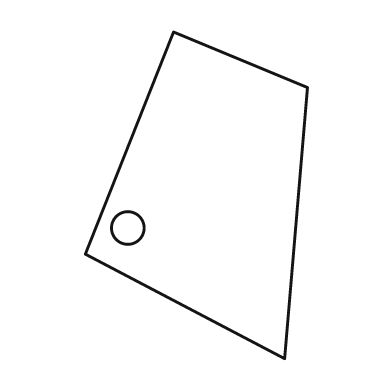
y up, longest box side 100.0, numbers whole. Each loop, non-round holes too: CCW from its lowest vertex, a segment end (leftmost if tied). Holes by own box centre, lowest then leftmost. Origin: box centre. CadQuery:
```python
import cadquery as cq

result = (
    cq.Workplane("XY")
    .moveTo(27.0, -50.0)
    .lineTo(34.0, 33.0)
    .lineTo(-7.0, 50.0)
    .lineTo(-34.0, -18.0)
    .close()
    .moveTo(-21.0, -10.0)
    .circle(5.0)
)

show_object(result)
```